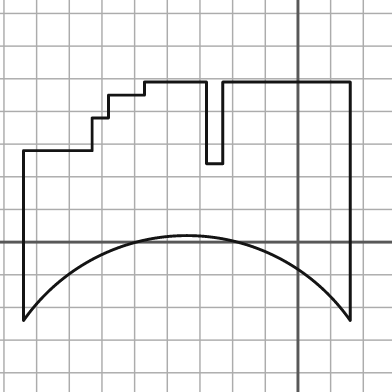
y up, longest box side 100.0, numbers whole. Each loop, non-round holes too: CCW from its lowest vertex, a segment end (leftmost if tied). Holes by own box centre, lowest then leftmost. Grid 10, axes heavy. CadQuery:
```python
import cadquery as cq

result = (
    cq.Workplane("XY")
    .moveTo(-84.0, -24.0)
    .threePointArc((-34.0, 2.0), (16.0, -24.0))
    .lineTo(16.0, 49.0)
    .lineTo(-23.0, 49.0)
    .lineTo(-23.0, 24.0)
    .lineTo(-28.0, 24.0)
    .lineTo(-28.0, 49.0)
    .lineTo(-47.0, 49.0)
    .lineTo(-47.0, 45.0)
    .lineTo(-58.0, 45.0)
    .lineTo(-58.0, 38.0)
    .lineTo(-63.0, 38.0)
    .lineTo(-63.0, 28.0)
    .lineTo(-84.0, 28.0)
    .close()
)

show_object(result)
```